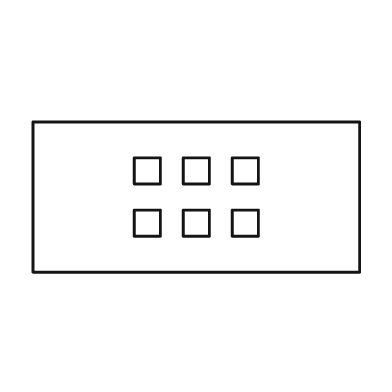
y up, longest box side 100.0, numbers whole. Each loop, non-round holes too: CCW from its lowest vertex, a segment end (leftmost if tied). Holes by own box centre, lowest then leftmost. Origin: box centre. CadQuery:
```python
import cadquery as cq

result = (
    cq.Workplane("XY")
    .moveTo(-50.0, -23.0)
    .lineTo(50.0, -23.0)
    .lineTo(50.0, 23.0)
    .lineTo(-50.0, 23.0)
    .close()
    .moveTo(-19.0, -12.0)
    .lineTo(-11.0, -12.0)
    .lineTo(-11.0, -4.0)
    .lineTo(-19.0, -4.0)
    .close()
    .moveTo(-4.0, -12.0)
    .lineTo(4.0, -12.0)
    .lineTo(4.0, -4.0)
    .lineTo(-4.0, -4.0)
    .close()
    .moveTo(11.0, -12.0)
    .lineTo(19.0, -12.0)
    .lineTo(19.0, -4.0)
    .lineTo(11.0, -4.0)
    .close()
    .moveTo(-19.0, 4.0)
    .lineTo(-11.0, 4.0)
    .lineTo(-11.0, 12.0)
    .lineTo(-19.0, 12.0)
    .close()
    .moveTo(-4.0, 4.0)
    .lineTo(4.0, 4.0)
    .lineTo(4.0, 12.0)
    .lineTo(-4.0, 12.0)
    .close()
    .moveTo(11.0, 4.0)
    .lineTo(19.0, 4.0)
    .lineTo(19.0, 12.0)
    .lineTo(11.0, 12.0)
    .close()
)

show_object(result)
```